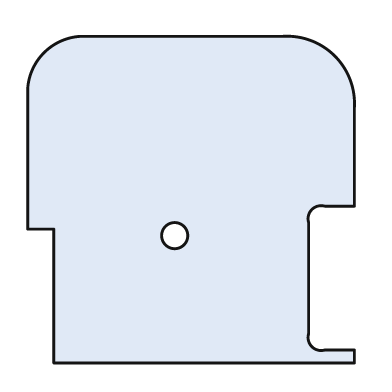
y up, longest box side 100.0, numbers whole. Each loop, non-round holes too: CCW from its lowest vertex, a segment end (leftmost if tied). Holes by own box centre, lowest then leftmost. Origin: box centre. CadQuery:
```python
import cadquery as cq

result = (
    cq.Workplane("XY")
    .moveTo(-42.0, -50.0)
    .lineTo(50.0, -50.0)
    .lineTo(50.0, -46.0)
    .lineTo(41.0, -46.0)
    .threePointArc((37.0, -45.0), (36.0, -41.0))
    .lineTo(36.0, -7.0)
    .threePointArc((37.0, -3.0), (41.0, -2.0))
    .lineTo(50.0, -2.0)
    .lineTo(50.0, 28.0)
    .threePointArc((44.0, 44.0), (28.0, 50.0))
    .lineTo(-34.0, 50.0)
    .threePointArc((-45.0, 45.0), (-50.0, 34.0))
    .lineTo(-50.0, -9.0)
    .lineTo(-42.0, -9.0)
    .close()
    .moveTo(-5.0, -11.0)
    .circle(4.0)
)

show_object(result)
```